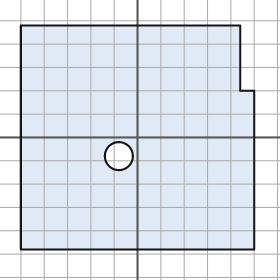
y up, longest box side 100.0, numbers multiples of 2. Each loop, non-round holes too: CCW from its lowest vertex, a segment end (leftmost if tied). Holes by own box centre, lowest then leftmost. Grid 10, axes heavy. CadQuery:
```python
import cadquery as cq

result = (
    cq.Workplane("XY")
    .moveTo(-50.0, -48.0)
    .lineTo(50.0, -48.0)
    .lineTo(50.0, 20.0)
    .lineTo(44.0, 20.0)
    .lineTo(44.0, 48.0)
    .lineTo(-50.0, 48.0)
    .close()
    .moveTo(-8.0, -8.0)
    .circle(6.0)
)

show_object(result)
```